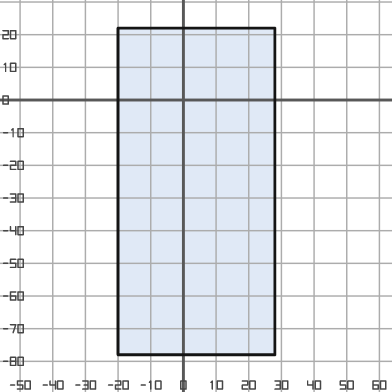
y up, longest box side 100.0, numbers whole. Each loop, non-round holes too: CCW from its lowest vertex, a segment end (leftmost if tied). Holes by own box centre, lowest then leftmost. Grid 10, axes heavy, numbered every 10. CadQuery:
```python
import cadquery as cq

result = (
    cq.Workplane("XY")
    .moveTo(-20.0, -78.0)
    .lineTo(28.0, -78.0)
    .lineTo(28.0, 22.0)
    .lineTo(-20.0, 22.0)
    .close()
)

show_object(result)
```